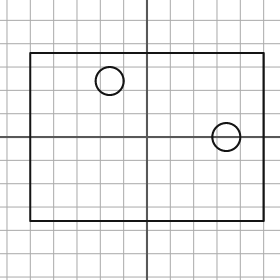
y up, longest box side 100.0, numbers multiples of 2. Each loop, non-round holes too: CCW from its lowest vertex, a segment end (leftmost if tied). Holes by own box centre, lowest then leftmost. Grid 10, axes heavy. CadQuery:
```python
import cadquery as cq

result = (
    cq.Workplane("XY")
    .moveTo(-50.0, -36.0)
    .lineTo(50.0, -36.0)
    .lineTo(50.0, 36.0)
    .lineTo(-50.0, 36.0)
    .close()
    .moveTo(34.0, 0.0)
    .circle(6.0)
    .moveTo(-16.0, 24.0)
    .circle(6.0)
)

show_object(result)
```